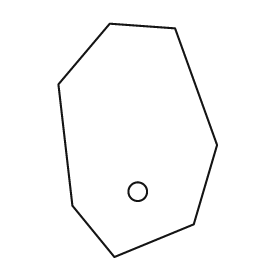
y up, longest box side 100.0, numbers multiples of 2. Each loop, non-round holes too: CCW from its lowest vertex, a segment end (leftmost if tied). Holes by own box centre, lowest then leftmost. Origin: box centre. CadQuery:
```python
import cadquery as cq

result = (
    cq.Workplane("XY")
    .moveTo(-10.0, -50.0)
    .lineTo(24.0, -36.0)
    .lineTo(34.0, -2.0)
    .lineTo(16.0, 48.0)
    .lineTo(-12.0, 50.0)
    .lineTo(-34.0, 24.0)
    .lineTo(-28.0, -28.0)
    .close()
    .moveTo(0.0, -22.0)
    .circle(4.0)
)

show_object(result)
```